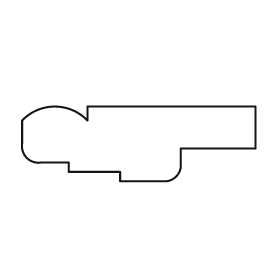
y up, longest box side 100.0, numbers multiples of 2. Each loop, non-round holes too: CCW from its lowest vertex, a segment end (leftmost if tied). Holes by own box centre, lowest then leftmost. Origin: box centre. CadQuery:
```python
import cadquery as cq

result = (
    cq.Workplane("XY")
    .moveTo(-8.0, -16.0)
    .lineTo(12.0, -16.0)
    .threePointArc((16.0, -14.0), (18.0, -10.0))
    .lineTo(18.0, -2.0)
    .lineTo(50.0, -2.0)
    .lineTo(50.0, 16.0)
    .lineTo(-22.0, 16.0)
    .lineTo(-22.0, 10.0)
    .threePointArc((-36.0, 16.0), (-50.0, 10.0))
    .lineTo(-50.0, 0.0)
    .threePointArc((-48.0, -6.0), (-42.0, -8.0))
    .lineTo(-30.0, -8.0)
    .lineTo(-30.0, -12.0)
    .lineTo(-8.0, -12.0)
    .close()
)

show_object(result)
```